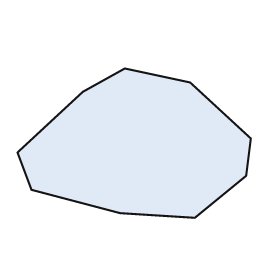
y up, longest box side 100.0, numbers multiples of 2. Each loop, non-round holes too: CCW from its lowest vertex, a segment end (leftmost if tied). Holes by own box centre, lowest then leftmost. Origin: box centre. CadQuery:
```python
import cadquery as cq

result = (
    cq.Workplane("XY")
    .moveTo(26.0, -32.0)
    .lineTo(48.0, -14.0)
    .lineTo(50.0, 2.0)
    .lineTo(24.0, 26.0)
    .lineTo(-4.0, 32.0)
    .lineTo(-22.0, 22.0)
    .lineTo(-50.0, -4.0)
    .lineTo(-44.0, -20.0)
    .lineTo(-6.0, -30.0)
    .close()
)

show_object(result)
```